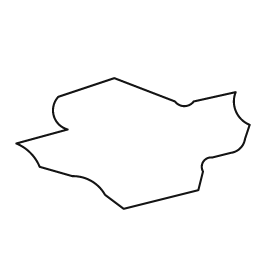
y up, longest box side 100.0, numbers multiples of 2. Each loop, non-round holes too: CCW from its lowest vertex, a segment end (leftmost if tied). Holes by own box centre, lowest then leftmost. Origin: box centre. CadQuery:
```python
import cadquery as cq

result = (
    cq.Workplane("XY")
    .moveTo(-4.0, -28.0)
    .lineTo(28.0, -20.0)
    .lineTo(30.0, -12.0)
    .threePointArc((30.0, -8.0), (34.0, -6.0))
    .lineTo(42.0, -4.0)
    .threePointArc((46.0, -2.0), (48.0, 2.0))
    .lineTo(50.0, 8.0)
    .threePointArc((44.0, 14.0), (44.0, 22.0))
    .lineTo(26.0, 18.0)
    .threePointArc((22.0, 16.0), (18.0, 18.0))
    .lineTo(-8.0, 28.0)
    .lineTo(-32.0, 20.0)
    .threePointArc((-34.0, 12.0), (-28.0, 6.0))
    .lineTo(-50.0, 0.0)
    .threePointArc((-44.0, -4.0), (-40.0, -10.0))
    .lineTo(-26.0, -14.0)
    .threePointArc((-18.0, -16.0), (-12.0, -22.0))
    .close()
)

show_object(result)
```